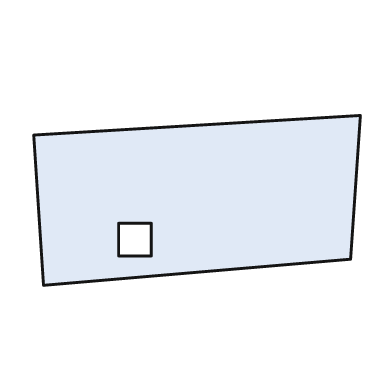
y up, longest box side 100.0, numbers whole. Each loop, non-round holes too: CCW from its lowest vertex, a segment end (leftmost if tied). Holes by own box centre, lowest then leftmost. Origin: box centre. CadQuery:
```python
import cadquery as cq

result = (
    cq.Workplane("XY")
    .moveTo(-47.0, -26.0)
    .lineTo(47.0, -18.0)
    .lineTo(50.0, 26.0)
    .lineTo(-50.0, 20.0)
    .close()
    .moveTo(-24.0, -17.0)
    .lineTo(-14.0, -17.0)
    .lineTo(-14.0, -7.0)
    .lineTo(-24.0, -7.0)
    .close()
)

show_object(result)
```